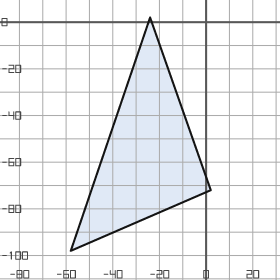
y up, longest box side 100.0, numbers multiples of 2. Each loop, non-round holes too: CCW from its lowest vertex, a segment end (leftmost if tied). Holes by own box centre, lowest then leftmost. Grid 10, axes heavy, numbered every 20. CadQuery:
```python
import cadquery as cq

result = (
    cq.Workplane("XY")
    .moveTo(-58.0, -98.0)
    .lineTo(2.0, -72.0)
    .lineTo(-24.0, 2.0)
    .close()
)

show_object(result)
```